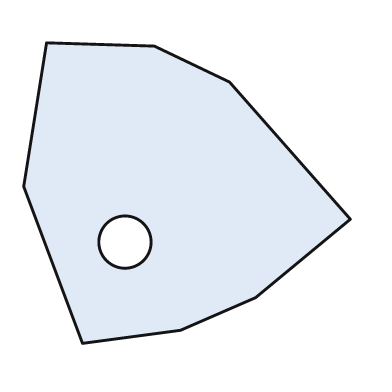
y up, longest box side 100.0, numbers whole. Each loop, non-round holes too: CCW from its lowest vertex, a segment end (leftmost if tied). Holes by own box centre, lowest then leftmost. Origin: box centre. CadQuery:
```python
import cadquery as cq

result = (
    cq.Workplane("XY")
    .moveTo(-32.0, -46.0)
    .lineTo(-2.0, -42.0)
    .lineTo(21.0, -32.0)
    .lineTo(50.0, -8.0)
    .lineTo(13.0, 34.0)
    .lineTo(-10.0, 45.0)
    .lineTo(-43.0, 46.0)
    .lineTo(-50.0, 2.0)
    .close()
    .moveTo(-19.0, -15.0)
    .circle(8.0)
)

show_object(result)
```